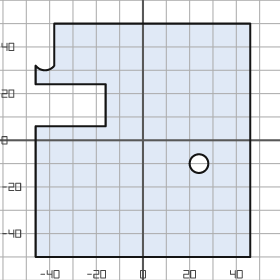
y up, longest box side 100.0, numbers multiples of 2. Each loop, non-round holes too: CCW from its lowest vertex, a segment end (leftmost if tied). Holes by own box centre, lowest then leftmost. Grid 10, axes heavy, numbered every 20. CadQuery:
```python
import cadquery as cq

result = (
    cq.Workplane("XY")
    .moveTo(-46.0, -50.0)
    .lineTo(46.0, -50.0)
    .lineTo(46.0, 50.0)
    .lineTo(-38.0, 50.0)
    .lineTo(-38.0, 32.0)
    .threePointArc((-42.0, 30.0), (-46.0, 32.0))
    .lineTo(-46.0, 24.0)
    .lineTo(-16.0, 24.0)
    .lineTo(-16.0, 6.0)
    .lineTo(-46.0, 6.0)
    .close()
    .moveTo(24.0, -10.0)
    .circle(4.0)
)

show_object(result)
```